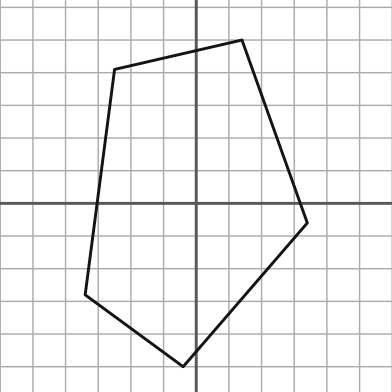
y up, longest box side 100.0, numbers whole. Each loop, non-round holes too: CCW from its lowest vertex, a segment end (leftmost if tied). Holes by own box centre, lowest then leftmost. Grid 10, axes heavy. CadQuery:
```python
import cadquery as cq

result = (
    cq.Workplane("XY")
    .moveTo(-4.0, -50.0)
    .lineTo(34.0, -6.0)
    .lineTo(14.0, 50.0)
    .lineTo(-25.0, 41.0)
    .lineTo(-34.0, -28.0)
    .close()
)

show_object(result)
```